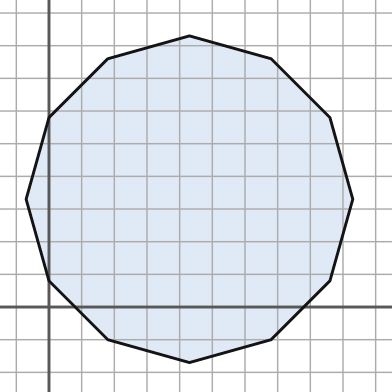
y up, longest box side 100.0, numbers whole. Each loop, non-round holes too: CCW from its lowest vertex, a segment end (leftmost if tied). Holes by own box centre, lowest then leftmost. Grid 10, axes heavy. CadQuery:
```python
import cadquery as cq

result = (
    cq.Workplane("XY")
    .moveTo(43.0, -17.0)
    .lineTo(68.0, -10.0)
    .lineTo(86.0, 8.0)
    .lineTo(93.0, 33.0)
    .lineTo(86.0, 58.0)
    .lineTo(68.0, 76.0)
    .lineTo(43.0, 83.0)
    .lineTo(18.0, 76.0)
    .lineTo(0.0, 58.0)
    .lineTo(-7.0, 33.0)
    .lineTo(0.0, 8.0)
    .lineTo(18.0, -10.0)
    .close()
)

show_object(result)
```